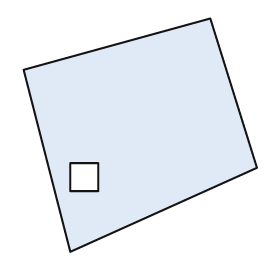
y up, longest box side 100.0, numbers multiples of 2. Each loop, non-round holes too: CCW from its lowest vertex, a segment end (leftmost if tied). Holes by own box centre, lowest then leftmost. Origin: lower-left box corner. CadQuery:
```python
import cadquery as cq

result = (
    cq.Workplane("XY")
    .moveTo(20.0, 0.0)
    .lineTo(100.0, 36.0)
    .lineTo(80.0, 100.0)
    .lineTo(0.0, 78.0)
    .close()
    .moveTo(20.0, 26.0)
    .lineTo(32.0, 26.0)
    .lineTo(32.0, 38.0)
    .lineTo(20.0, 38.0)
    .close()
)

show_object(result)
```